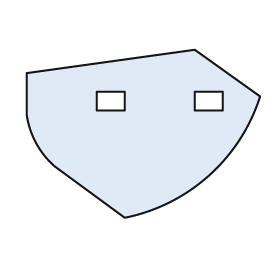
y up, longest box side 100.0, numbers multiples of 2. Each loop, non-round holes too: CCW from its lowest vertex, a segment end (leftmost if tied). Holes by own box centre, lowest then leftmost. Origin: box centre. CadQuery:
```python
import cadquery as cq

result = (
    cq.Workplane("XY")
    .moveTo(-8.0, -36.0)
    .threePointArc((28.0, -18.0), (50.0, 16.0))
    .lineTo(22.0, 36.0)
    .lineTo(-50.0, 26.0)
    .lineTo(-50.0, 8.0)
    .threePointArc((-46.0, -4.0), (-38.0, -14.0))
    .close()
    .moveTo(-20.0, 10.0)
    .lineTo(-8.0, 10.0)
    .lineTo(-8.0, 18.0)
    .lineTo(-20.0, 18.0)
    .close()
    .moveTo(22.0, 10.0)
    .lineTo(34.0, 10.0)
    .lineTo(34.0, 18.0)
    .lineTo(22.0, 18.0)
    .close()
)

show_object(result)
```